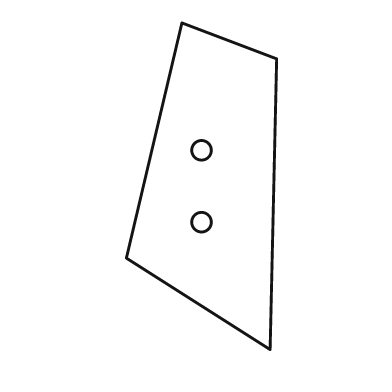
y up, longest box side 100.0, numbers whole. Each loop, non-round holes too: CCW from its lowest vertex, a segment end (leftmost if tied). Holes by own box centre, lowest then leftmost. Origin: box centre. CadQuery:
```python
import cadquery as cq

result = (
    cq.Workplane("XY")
    .moveTo(21.0, -50.0)
    .lineTo(23.0, 39.0)
    .lineTo(-6.0, 50.0)
    .lineTo(-23.0, -22.0)
    .close()
    .moveTo(0.0, -11.0)
    .circle(3.0)
    .moveTo(0.0, 11.0)
    .circle(3.0)
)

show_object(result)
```